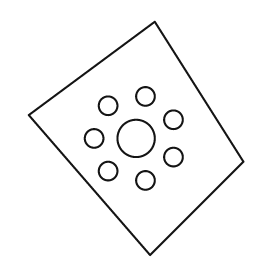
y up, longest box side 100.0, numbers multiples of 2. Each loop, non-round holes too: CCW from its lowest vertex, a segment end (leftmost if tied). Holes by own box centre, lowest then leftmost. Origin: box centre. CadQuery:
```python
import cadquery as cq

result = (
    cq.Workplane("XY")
    .moveTo(6.0, -50.0)
    .lineTo(46.0, -10.0)
    .lineTo(8.0, 50.0)
    .lineTo(-46.0, 10.0)
    .close()
    .moveTo(4.0, -18.0)
    .circle(4.0)
    .moveTo(-12.0, -14.0)
    .circle(4.0)
    .moveTo(16.0, -8.0)
    .circle(4.0)
    .moveTo(-18.0, 0.0)
    .circle(4.0)
    .moveTo(0.0, 0.0)
    .circle(8.0)
    .moveTo(16.0, 8.0)
    .circle(4.0)
    .moveTo(-12.0, 14.0)
    .circle(4.0)
    .moveTo(4.0, 18.0)
    .circle(4.0)
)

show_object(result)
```